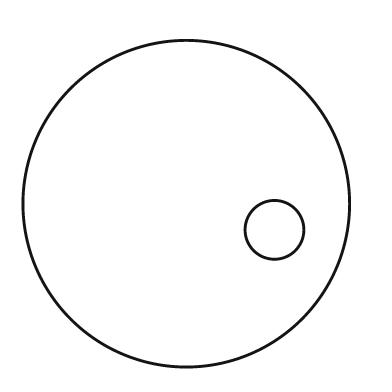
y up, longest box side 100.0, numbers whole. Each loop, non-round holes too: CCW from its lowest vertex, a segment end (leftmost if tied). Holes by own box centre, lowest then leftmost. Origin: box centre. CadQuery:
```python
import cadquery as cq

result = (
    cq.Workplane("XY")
    .moveTo(0.0, 0.0)
    .circle(50.0)
    .moveTo(27.0, -8.0)
    .circle(9.0)
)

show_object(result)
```